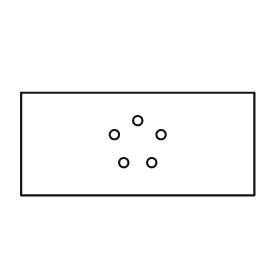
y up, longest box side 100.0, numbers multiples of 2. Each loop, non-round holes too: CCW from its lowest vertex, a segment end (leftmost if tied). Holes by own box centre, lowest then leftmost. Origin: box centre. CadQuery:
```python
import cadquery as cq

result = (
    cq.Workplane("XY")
    .moveTo(-50.0, -22.0)
    .lineTo(50.0, -22.0)
    .lineTo(50.0, 22.0)
    .lineTo(-50.0, 22.0)
    .close()
    .moveTo(-6.0, -8.0)
    .circle(2.0)
    .moveTo(6.0, -8.0)
    .circle(2.0)
    .moveTo(-10.0, 4.0)
    .circle(2.0)
    .moveTo(10.0, 4.0)
    .circle(2.0)
    .moveTo(0.0, 10.0)
    .circle(2.0)
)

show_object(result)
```